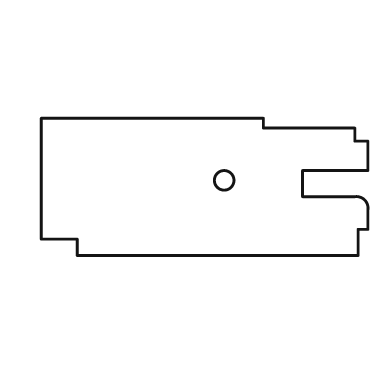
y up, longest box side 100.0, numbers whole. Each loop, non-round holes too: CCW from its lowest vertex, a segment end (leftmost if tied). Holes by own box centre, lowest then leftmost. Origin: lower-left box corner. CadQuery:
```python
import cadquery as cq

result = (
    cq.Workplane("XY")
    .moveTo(11.0, 0.0)
    .lineTo(97.0, 0.0)
    .lineTo(97.0, 8.0)
    .lineTo(100.0, 8.0)
    .lineTo(100.0, 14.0)
    .threePointArc((99.0, 17.0), (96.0, 18.0))
    .lineTo(80.0, 18.0)
    .lineTo(80.0, 26.0)
    .lineTo(100.0, 26.0)
    .lineTo(100.0, 35.0)
    .lineTo(96.0, 35.0)
    .lineTo(96.0, 39.0)
    .lineTo(68.0, 39.0)
    .lineTo(68.0, 42.0)
    .lineTo(0.0, 42.0)
    .lineTo(0.0, 5.0)
    .lineTo(11.0, 5.0)
    .close()
    .moveTo(56.0, 23.0)
    .circle(3.0)
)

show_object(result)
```